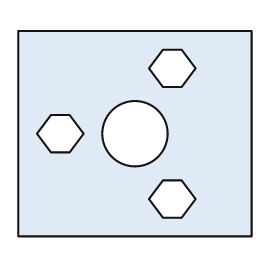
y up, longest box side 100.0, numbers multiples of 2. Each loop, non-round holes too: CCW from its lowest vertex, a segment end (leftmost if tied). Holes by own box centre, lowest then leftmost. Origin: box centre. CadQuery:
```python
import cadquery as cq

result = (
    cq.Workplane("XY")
    .moveTo(-50.0, -44.0)
    .lineTo(50.0, -44.0)
    .lineTo(50.0, 44.0)
    .lineTo(-50.0, 44.0)
    .close()
    .moveTo(12.0, -36.0)
    .lineTo(20.0, -36.0)
    .lineTo(26.0, -28.0)
    .lineTo(20.0, -20.0)
    .lineTo(12.0, -20.0)
    .lineTo(6.0, -28.0)
    .close()
    .moveTo(-36.0, -8.0)
    .lineTo(-28.0, -8.0)
    .lineTo(-22.0, 0.0)
    .lineTo(-28.0, 8.0)
    .lineTo(-36.0, 8.0)
    .lineTo(-42.0, 0.0)
    .close()
    .moveTo(0.0, 0.0)
    .circle(14.0)
    .moveTo(12.0, 20.0)
    .lineTo(20.0, 20.0)
    .lineTo(26.0, 28.0)
    .lineTo(20.0, 36.0)
    .lineTo(12.0, 36.0)
    .lineTo(6.0, 28.0)
    .close()
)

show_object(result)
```